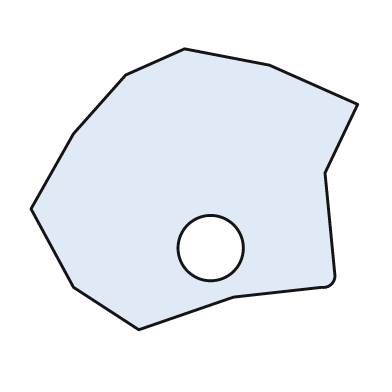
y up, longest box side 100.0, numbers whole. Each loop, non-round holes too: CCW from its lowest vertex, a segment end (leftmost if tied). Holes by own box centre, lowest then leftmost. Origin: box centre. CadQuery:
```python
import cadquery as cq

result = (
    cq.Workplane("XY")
    .moveTo(-17.0, -43.0)
    .lineTo(12.0, -33.0)
    .lineTo(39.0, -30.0)
    .threePointArc((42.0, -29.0), (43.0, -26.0))
    .lineTo(40.0, 5.0)
    .lineTo(50.0, 26.0)
    .lineTo(23.0, 38.0)
    .lineTo(-3.0, 43.0)
    .lineTo(-21.0, 35.0)
    .lineTo(-37.0, 17.0)
    .lineTo(-50.0, -6.0)
    .lineTo(-37.0, -30.0)
    .close()
    .moveTo(5.0, -18.0)
    .circle(10.0)
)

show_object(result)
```